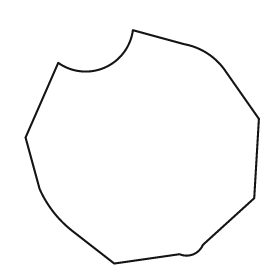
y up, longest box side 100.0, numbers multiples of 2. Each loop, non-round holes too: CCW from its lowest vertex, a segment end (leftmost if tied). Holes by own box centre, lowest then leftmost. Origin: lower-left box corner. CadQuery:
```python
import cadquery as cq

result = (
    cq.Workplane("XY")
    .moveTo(38.0, 0.0)
    .lineTo(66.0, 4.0)
    .threePointArc((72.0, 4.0), (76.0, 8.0))
    .lineTo(98.0, 28.0)
    .lineTo(100.0, 62.0)
    .lineTo(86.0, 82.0)
    .threePointArc((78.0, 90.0), (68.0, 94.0))
    .lineTo(46.0, 100.0)
    .threePointArc((34.0, 84.0), (14.0, 86.0))
    .lineTo(0.0, 54.0)
    .lineTo(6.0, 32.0)
    .threePointArc((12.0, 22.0), (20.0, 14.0))
    .close()
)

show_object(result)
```